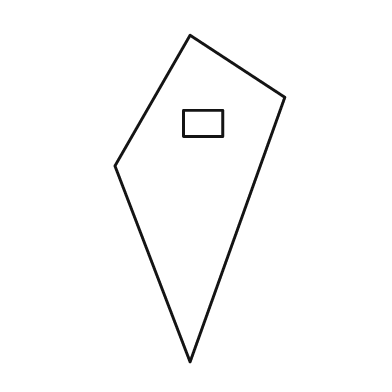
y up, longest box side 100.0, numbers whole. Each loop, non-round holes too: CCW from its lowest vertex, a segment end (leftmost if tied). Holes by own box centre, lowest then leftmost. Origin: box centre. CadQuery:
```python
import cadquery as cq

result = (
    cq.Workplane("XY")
    .moveTo(-3.0, -50.0)
    .lineTo(26.0, 31.0)
    .lineTo(-3.0, 50.0)
    .lineTo(-26.0, 10.0)
    .close()
    .moveTo(-5.0, 19.0)
    .lineTo(7.0, 19.0)
    .lineTo(7.0, 27.0)
    .lineTo(-5.0, 27.0)
    .close()
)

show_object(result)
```